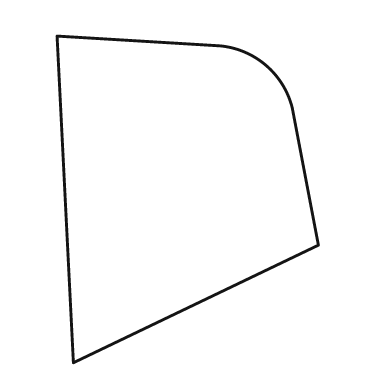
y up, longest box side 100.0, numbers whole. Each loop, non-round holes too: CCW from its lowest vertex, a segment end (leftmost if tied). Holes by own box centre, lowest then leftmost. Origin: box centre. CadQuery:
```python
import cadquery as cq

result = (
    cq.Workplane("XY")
    .moveTo(-35.0, -50.0)
    .lineTo(40.0, -14.0)
    .lineTo(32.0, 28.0)
    .threePointArc((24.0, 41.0), (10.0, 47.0))
    .lineTo(-40.0, 50.0)
    .close()
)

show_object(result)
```